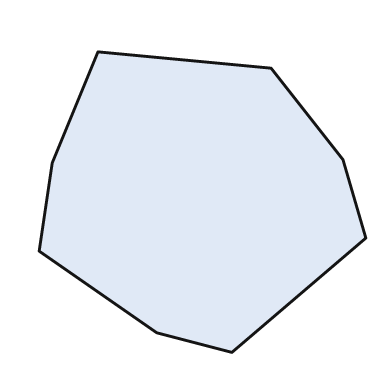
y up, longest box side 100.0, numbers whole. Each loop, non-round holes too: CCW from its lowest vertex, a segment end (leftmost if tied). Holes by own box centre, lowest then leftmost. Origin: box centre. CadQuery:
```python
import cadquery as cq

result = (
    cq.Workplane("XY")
    .moveTo(9.0, -46.0)
    .lineTo(50.0, -11.0)
    .lineTo(43.0, 13.0)
    .lineTo(21.0, 41.0)
    .lineTo(-32.0, 46.0)
    .lineTo(-46.0, 12.0)
    .lineTo(-50.0, -15.0)
    .lineTo(-14.0, -40.0)
    .close()
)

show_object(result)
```